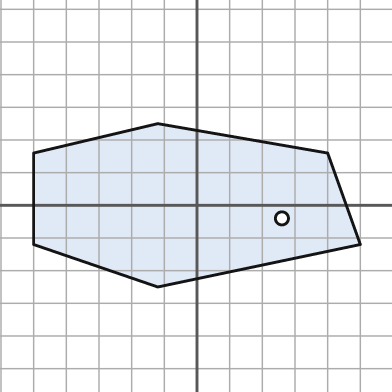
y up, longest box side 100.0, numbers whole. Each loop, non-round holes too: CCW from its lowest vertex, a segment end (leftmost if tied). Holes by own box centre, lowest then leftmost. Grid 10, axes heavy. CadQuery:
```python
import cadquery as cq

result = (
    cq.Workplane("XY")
    .moveTo(-12.0, -25.0)
    .lineTo(50.0, -12.0)
    .lineTo(40.0, 16.0)
    .lineTo(-12.0, 25.0)
    .lineTo(-50.0, 16.0)
    .lineTo(-50.0, -12.0)
    .close()
    .moveTo(26.0, -4.0)
    .circle(2.0)
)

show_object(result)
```